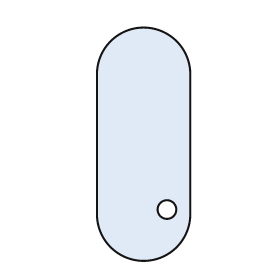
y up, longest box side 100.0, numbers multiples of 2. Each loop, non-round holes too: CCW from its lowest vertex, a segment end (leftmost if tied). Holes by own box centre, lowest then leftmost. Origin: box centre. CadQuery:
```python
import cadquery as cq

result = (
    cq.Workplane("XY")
    .moveTo(-20.0, -30.0)
    .threePointArc((0.0, -50.0), (20.0, -30.0))
    .lineTo(20.0, 30.0)
    .threePointArc((0.0, 50.0), (-20.0, 30.0))
    .close()
    .moveTo(10.0, -28.0)
    .circle(4.0)
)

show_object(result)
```